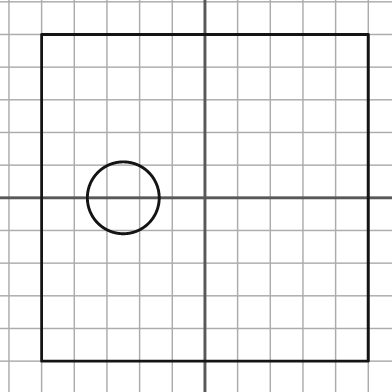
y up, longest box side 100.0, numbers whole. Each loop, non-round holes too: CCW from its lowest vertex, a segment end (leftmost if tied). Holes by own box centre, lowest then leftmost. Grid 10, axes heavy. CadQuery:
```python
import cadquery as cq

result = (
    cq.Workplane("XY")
    .moveTo(-50.0, -50.0)
    .lineTo(50.0, -50.0)
    .lineTo(50.0, 50.0)
    .lineTo(-50.0, 50.0)
    .close()
    .moveTo(-25.0, 0.0)
    .circle(11.0)
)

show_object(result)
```